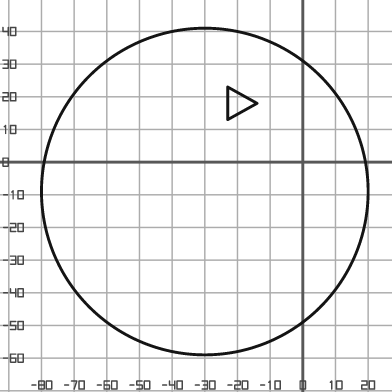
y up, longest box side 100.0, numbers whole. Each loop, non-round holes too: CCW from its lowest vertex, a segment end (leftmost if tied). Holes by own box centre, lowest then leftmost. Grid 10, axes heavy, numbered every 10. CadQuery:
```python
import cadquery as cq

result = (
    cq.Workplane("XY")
    .moveTo(-30.0, -9.0)
    .circle(50.0)
    .moveTo(-23.0, 13.0)
    .lineTo(-14.0, 18.0)
    .lineTo(-23.0, 23.0)
    .close()
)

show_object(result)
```